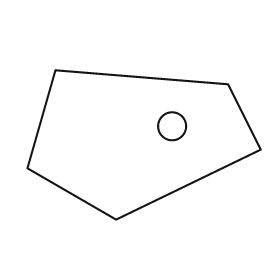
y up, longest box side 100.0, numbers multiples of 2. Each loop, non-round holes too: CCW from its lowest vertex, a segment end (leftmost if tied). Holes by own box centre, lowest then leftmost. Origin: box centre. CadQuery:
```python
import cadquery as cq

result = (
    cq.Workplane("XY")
    .moveTo(-12.0, -32.0)
    .lineTo(50.0, -2.0)
    .lineTo(36.0, 26.0)
    .lineTo(-38.0, 32.0)
    .lineTo(-50.0, -10.0)
    .close()
    .moveTo(12.0, 8.0)
    .circle(6.0)
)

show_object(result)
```